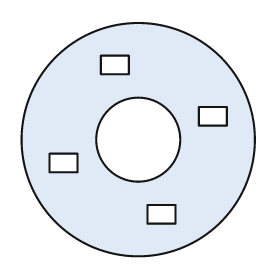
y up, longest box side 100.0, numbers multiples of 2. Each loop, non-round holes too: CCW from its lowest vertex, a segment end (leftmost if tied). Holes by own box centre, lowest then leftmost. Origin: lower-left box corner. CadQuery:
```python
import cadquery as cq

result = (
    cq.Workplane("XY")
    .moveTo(50.0, 50.0)
    .circle(50.0)
    .moveTo(54.0, 14.0)
    .lineTo(66.0, 14.0)
    .lineTo(66.0, 22.0)
    .lineTo(54.0, 22.0)
    .close()
    .moveTo(12.0, 36.0)
    .lineTo(24.0, 36.0)
    .lineTo(24.0, 44.0)
    .lineTo(12.0, 44.0)
    .close()
    .moveTo(50.0, 50.0)
    .circle(18.0)
    .moveTo(76.0, 56.0)
    .lineTo(88.0, 56.0)
    .lineTo(88.0, 64.0)
    .lineTo(76.0, 64.0)
    .close()
    .moveTo(34.0, 78.0)
    .lineTo(46.0, 78.0)
    .lineTo(46.0, 86.0)
    .lineTo(34.0, 86.0)
    .close()
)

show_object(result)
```